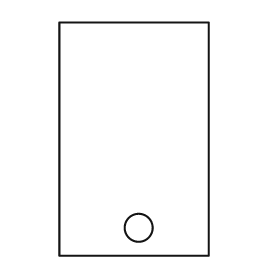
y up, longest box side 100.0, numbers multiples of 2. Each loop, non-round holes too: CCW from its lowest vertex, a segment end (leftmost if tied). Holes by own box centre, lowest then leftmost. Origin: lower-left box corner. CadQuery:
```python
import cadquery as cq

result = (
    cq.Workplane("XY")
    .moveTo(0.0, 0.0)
    .lineTo(64.0, 0.0)
    .lineTo(64.0, 100.0)
    .lineTo(0.0, 100.0)
    .close()
    .moveTo(34.0, 12.0)
    .circle(6.0)
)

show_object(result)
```